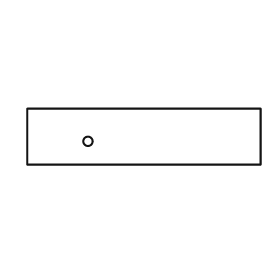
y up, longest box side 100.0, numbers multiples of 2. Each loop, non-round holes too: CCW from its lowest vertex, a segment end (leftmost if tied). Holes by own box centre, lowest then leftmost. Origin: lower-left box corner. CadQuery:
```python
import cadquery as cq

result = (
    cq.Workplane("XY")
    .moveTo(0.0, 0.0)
    .lineTo(100.0, 0.0)
    .lineTo(100.0, 24.0)
    .lineTo(0.0, 24.0)
    .close()
    .moveTo(26.0, 10.0)
    .circle(2.0)
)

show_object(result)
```